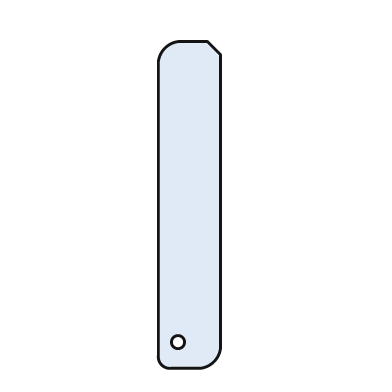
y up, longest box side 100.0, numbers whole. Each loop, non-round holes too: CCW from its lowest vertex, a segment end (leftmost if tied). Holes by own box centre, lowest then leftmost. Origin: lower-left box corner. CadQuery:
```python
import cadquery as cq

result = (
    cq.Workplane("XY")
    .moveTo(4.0, 0.0)
    .lineTo(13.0, 0.0)
    .threePointArc((17.0, 2.0), (19.0, 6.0))
    .lineTo(19.0, 96.0)
    .lineTo(15.0, 100.0)
    .lineTo(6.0, 100.0)
    .threePointArc((2.0, 98.0), (0.0, 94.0))
    .lineTo(0.0, 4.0)
    .threePointArc((1.0, 1.0), (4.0, 0.0))
    .close()
    .moveTo(6.0, 8.0)
    .circle(2.0)
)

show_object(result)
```